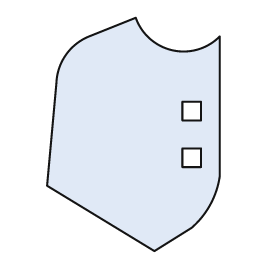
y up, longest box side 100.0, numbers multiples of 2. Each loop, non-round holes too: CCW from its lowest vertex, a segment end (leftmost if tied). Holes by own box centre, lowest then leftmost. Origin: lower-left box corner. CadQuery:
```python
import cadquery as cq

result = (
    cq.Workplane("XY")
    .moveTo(46.0, 0.0)
    .lineTo(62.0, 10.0)
    .threePointArc((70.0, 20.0), (74.0, 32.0))
    .lineTo(74.0, 92.0)
    .threePointArc((54.0, 86.0), (38.0, 100.0))
    .lineTo(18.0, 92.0)
    .threePointArc((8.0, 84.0), (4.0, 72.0))
    .lineTo(0.0, 28.0)
    .close()
    .moveTo(58.0, 36.0)
    .lineTo(66.0, 36.0)
    .lineTo(66.0, 44.0)
    .lineTo(58.0, 44.0)
    .close()
    .moveTo(58.0, 56.0)
    .lineTo(66.0, 56.0)
    .lineTo(66.0, 64.0)
    .lineTo(58.0, 64.0)
    .close()
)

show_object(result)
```